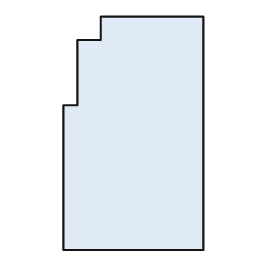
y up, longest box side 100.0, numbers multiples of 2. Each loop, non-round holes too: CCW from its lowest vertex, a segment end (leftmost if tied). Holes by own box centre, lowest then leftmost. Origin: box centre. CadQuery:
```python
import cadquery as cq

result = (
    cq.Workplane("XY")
    .moveTo(-30.0, -50.0)
    .lineTo(30.0, -50.0)
    .lineTo(30.0, 50.0)
    .lineTo(-14.0, 50.0)
    .lineTo(-14.0, 40.0)
    .lineTo(-24.0, 40.0)
    .lineTo(-24.0, 12.0)
    .lineTo(-30.0, 12.0)
    .close()
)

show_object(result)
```